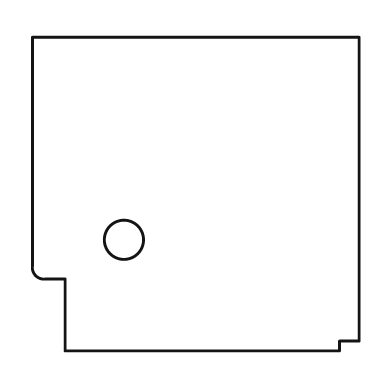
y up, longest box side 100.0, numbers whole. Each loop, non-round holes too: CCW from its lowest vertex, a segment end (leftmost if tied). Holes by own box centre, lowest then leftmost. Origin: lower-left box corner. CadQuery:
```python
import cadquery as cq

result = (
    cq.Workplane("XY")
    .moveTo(10.0, 0.0)
    .lineTo(94.0, 0.0)
    .lineTo(94.0, 3.0)
    .lineTo(100.0, 3.0)
    .lineTo(100.0, 96.0)
    .lineTo(0.0, 96.0)
    .lineTo(0.0, 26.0)
    .threePointArc((1.0, 23.0), (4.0, 22.0))
    .lineTo(10.0, 22.0)
    .close()
    .moveTo(28.0, 34.0)
    .circle(6.0)
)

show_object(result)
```